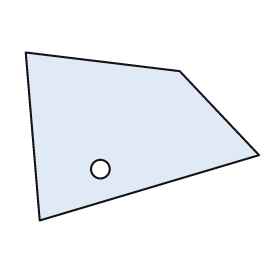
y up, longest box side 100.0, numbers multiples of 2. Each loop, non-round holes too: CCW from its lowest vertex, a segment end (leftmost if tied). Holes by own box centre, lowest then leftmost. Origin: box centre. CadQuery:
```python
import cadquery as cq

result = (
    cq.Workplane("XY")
    .moveTo(-44.0, -36.0)
    .lineTo(50.0, -8.0)
    .lineTo(16.0, 28.0)
    .lineTo(-50.0, 36.0)
    .close()
    .moveTo(-18.0, -14.0)
    .circle(4.0)
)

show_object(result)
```